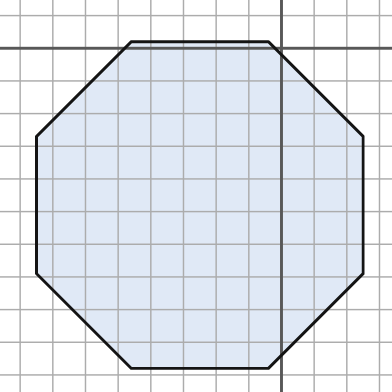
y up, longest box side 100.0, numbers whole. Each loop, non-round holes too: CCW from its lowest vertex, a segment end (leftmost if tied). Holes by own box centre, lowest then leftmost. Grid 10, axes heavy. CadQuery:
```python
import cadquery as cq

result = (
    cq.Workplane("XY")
    .moveTo(-46.0, -98.0)
    .lineTo(-4.0, -98.0)
    .lineTo(25.0, -69.0)
    .lineTo(25.0, -27.0)
    .lineTo(-4.0, 2.0)
    .lineTo(-46.0, 2.0)
    .lineTo(-75.0, -27.0)
    .lineTo(-75.0, -69.0)
    .close()
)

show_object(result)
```